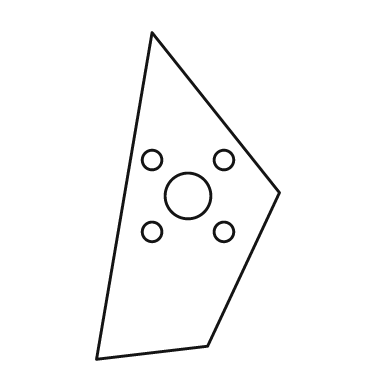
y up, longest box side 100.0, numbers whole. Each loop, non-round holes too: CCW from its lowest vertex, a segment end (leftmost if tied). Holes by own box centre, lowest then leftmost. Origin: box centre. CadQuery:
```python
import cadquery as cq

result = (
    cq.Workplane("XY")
    .moveTo(-28.0, -50.0)
    .lineTo(6.0, -46.0)
    .lineTo(28.0, 1.0)
    .lineTo(-11.0, 50.0)
    .close()
    .moveTo(-11.0, -11.0)
    .circle(3.0)
    .moveTo(11.0, -11.0)
    .circle(3.0)
    .moveTo(0.0, 0.0)
    .circle(7.0)
    .moveTo(-11.0, 11.0)
    .circle(3.0)
    .moveTo(11.0, 11.0)
    .circle(3.0)
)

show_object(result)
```